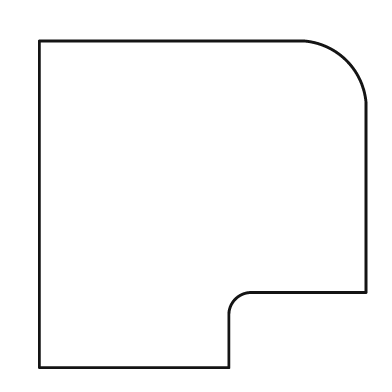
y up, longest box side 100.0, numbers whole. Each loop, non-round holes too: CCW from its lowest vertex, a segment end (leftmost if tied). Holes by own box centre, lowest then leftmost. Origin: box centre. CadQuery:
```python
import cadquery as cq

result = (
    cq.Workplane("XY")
    .moveTo(-50.0, -50.0)
    .lineTo(8.0, -50.0)
    .lineTo(8.0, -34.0)
    .threePointArc((10.0, -29.0), (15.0, -27.0))
    .lineTo(50.0, -27.0)
    .lineTo(50.0, 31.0)
    .threePointArc((44.0, 44.0), (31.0, 50.0))
    .lineTo(-50.0, 50.0)
    .close()
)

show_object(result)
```